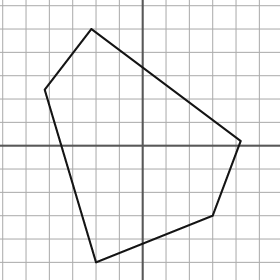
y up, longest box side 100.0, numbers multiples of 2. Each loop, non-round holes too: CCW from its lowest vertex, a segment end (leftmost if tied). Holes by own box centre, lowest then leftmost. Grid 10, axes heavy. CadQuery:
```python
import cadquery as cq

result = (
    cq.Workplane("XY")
    .moveTo(-20.0, -50.0)
    .lineTo(30.0, -30.0)
    .lineTo(42.0, 2.0)
    .lineTo(-22.0, 50.0)
    .lineTo(-42.0, 24.0)
    .close()
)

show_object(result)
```